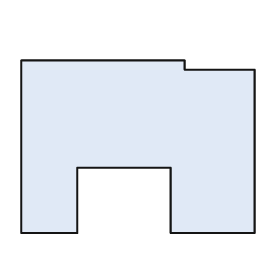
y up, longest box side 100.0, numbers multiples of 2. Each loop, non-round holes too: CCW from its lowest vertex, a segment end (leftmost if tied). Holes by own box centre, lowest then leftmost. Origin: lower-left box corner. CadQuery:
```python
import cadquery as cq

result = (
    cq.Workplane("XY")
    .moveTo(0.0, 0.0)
    .lineTo(24.0, 0.0)
    .lineTo(24.0, 28.0)
    .lineTo(64.0, 28.0)
    .lineTo(64.0, 0.0)
    .lineTo(100.0, 0.0)
    .lineTo(100.0, 70.0)
    .lineTo(70.0, 70.0)
    .lineTo(70.0, 74.0)
    .lineTo(0.0, 74.0)
    .close()
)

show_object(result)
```